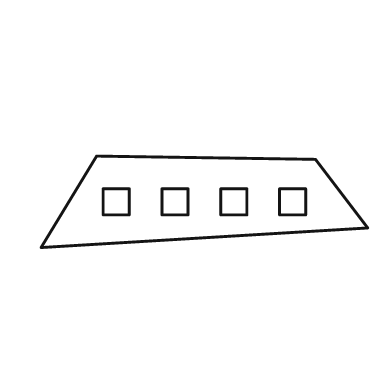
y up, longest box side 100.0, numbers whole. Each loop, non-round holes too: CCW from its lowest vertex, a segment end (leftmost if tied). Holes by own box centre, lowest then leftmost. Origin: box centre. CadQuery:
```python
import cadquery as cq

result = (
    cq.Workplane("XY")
    .moveTo(-50.0, -14.0)
    .lineTo(50.0, -8.0)
    .lineTo(34.0, 13.0)
    .lineTo(-33.0, 14.0)
    .close()
    .moveTo(-31.0, -4.0)
    .lineTo(-23.0, -4.0)
    .lineTo(-23.0, 4.0)
    .lineTo(-31.0, 4.0)
    .close()
    .moveTo(-13.0, -4.0)
    .lineTo(-5.0, -4.0)
    .lineTo(-5.0, 4.0)
    .lineTo(-13.0, 4.0)
    .close()
    .moveTo(5.0, -4.0)
    .lineTo(13.0, -4.0)
    .lineTo(13.0, 4.0)
    .lineTo(5.0, 4.0)
    .close()
    .moveTo(23.0, -4.0)
    .lineTo(31.0, -4.0)
    .lineTo(31.0, 4.0)
    .lineTo(23.0, 4.0)
    .close()
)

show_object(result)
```